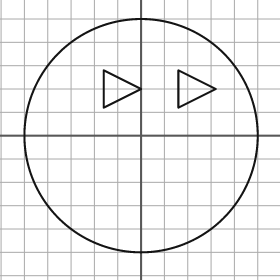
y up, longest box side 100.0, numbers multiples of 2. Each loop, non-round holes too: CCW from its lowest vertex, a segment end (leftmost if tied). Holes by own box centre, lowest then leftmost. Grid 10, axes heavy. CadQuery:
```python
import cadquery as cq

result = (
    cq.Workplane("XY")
    .moveTo(0.0, 0.0)
    .circle(50.0)
    .moveTo(-16.0, 12.0)
    .lineTo(0.0, 20.0)
    .lineTo(-16.0, 28.0)
    .close()
    .moveTo(16.0, 12.0)
    .lineTo(32.0, 20.0)
    .lineTo(16.0, 28.0)
    .close()
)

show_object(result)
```